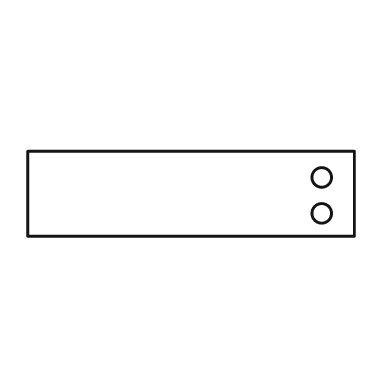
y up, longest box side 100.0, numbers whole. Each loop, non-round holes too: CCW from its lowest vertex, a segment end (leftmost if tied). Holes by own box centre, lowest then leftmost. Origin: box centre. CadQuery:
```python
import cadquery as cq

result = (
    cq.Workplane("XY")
    .moveTo(-50.0, -13.0)
    .lineTo(50.0, -13.0)
    .lineTo(50.0, 13.0)
    .lineTo(-50.0, 13.0)
    .close()
    .moveTo(40.0, -6.0)
    .circle(3.0)
    .moveTo(40.0, 5.0)
    .circle(3.0)
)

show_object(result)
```